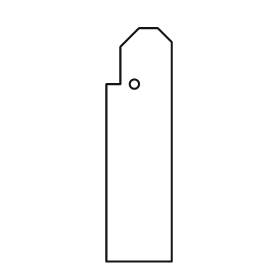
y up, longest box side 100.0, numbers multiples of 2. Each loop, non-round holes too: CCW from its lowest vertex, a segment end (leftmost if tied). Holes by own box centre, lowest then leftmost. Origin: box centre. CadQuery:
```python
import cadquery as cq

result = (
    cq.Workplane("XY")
    .moveTo(-14.0, -50.0)
    .lineTo(14.0, -50.0)
    .lineTo(14.0, 44.0)
    .lineTo(8.0, 50.0)
    .lineTo(0.0, 50.0)
    .lineTo(-8.0, 42.0)
    .lineTo(-8.0, 26.0)
    .lineTo(-14.0, 26.0)
    .close()
    .moveTo(-2.0, 26.0)
    .circle(2.0)
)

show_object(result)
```